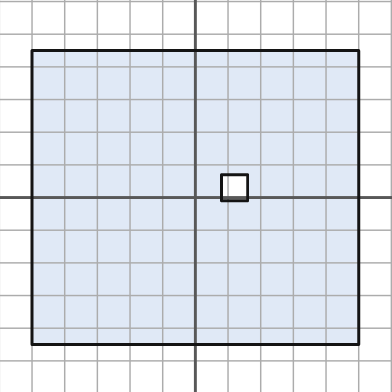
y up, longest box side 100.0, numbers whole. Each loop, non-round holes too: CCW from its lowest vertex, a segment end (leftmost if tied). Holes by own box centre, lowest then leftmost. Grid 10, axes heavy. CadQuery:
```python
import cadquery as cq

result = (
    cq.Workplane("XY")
    .moveTo(-50.0, -45.0)
    .lineTo(50.0, -45.0)
    .lineTo(50.0, 45.0)
    .lineTo(-50.0, 45.0)
    .close()
    .moveTo(8.0, -1.0)
    .lineTo(16.0, -1.0)
    .lineTo(16.0, 7.0)
    .lineTo(8.0, 7.0)
    .close()
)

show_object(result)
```